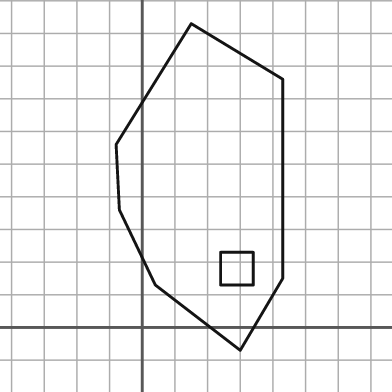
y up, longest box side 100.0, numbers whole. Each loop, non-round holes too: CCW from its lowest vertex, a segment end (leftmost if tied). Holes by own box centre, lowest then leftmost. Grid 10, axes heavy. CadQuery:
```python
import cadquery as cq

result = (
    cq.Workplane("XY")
    .moveTo(30.0, -7.0)
    .lineTo(43.0, 15.0)
    .lineTo(43.0, 76.0)
    .lineTo(15.0, 93.0)
    .lineTo(-8.0, 56.0)
    .lineTo(-7.0, 36.0)
    .lineTo(4.0, 13.0)
    .close()
    .moveTo(24.0, 13.0)
    .lineTo(34.0, 13.0)
    .lineTo(34.0, 23.0)
    .lineTo(24.0, 23.0)
    .close()
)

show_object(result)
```